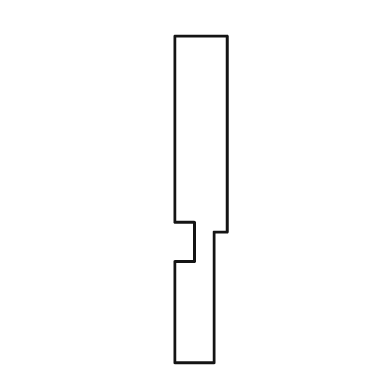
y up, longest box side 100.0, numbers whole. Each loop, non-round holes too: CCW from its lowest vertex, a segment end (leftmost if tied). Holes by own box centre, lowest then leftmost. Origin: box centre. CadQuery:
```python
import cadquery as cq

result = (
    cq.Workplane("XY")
    .moveTo(-8.0, -50.0)
    .lineTo(4.0, -50.0)
    .lineTo(4.0, -10.0)
    .lineTo(8.0, -10.0)
    .lineTo(8.0, 50.0)
    .lineTo(-8.0, 50.0)
    .lineTo(-8.0, -7.0)
    .lineTo(-2.0, -7.0)
    .lineTo(-2.0, -19.0)
    .lineTo(-8.0, -19.0)
    .close()
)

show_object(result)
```